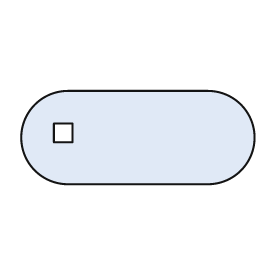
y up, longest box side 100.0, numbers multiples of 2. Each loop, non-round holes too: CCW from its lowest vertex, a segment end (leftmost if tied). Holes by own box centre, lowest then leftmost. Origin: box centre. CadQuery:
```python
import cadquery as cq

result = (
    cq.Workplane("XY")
    .moveTo(-30.0, -20.0)
    .lineTo(30.0, -20.0)
    .threePointArc((50.0, 0.0), (30.0, 20.0))
    .lineTo(-30.0, 20.0)
    .threePointArc((-50.0, 0.0), (-30.0, -20.0))
    .close()
    .moveTo(-36.0, -2.0)
    .lineTo(-28.0, -2.0)
    .lineTo(-28.0, 6.0)
    .lineTo(-36.0, 6.0)
    .close()
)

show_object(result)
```